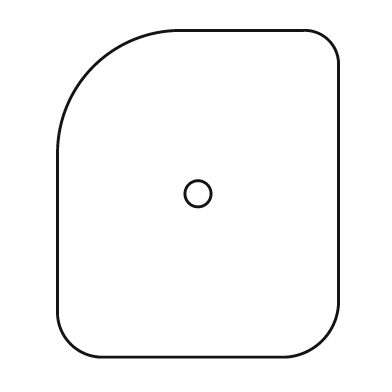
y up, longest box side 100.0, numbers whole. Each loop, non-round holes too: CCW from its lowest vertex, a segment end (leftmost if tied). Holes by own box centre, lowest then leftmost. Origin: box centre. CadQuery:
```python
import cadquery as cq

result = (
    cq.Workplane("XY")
    .moveTo(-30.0, -50.0)
    .lineTo(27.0, -50.0)
    .threePointArc((38.0, -45.0), (43.0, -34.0))
    .lineTo(43.0, 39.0)
    .threePointArc((40.0, 47.0), (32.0, 50.0))
    .lineTo(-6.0, 50.0)
    .threePointArc((-32.0, 39.0), (-43.0, 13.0))
    .lineTo(-43.0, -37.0)
    .threePointArc((-39.0, -46.0), (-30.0, -50.0))
    .close()
    .moveTo(0.0, 0.0)
    .circle(4.0)
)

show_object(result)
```